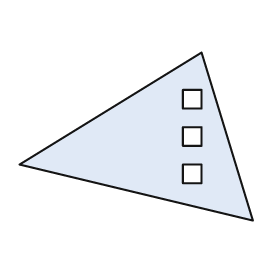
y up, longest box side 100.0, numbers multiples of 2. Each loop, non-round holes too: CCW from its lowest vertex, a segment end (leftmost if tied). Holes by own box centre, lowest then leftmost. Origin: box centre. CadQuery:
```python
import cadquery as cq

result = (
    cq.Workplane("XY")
    .moveTo(50.0, -36.0)
    .lineTo(28.0, 36.0)
    .lineTo(-50.0, -12.0)
    .close()
    .moveTo(20.0, -20.0)
    .lineTo(28.0, -20.0)
    .lineTo(28.0, -12.0)
    .lineTo(20.0, -12.0)
    .close()
    .moveTo(20.0, -4.0)
    .lineTo(28.0, -4.0)
    .lineTo(28.0, 4.0)
    .lineTo(20.0, 4.0)
    .close()
    .moveTo(20.0, 12.0)
    .lineTo(28.0, 12.0)
    .lineTo(28.0, 20.0)
    .lineTo(20.0, 20.0)
    .close()
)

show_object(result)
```